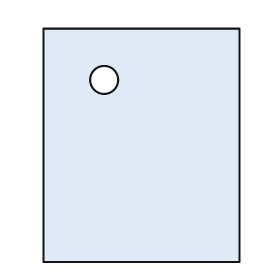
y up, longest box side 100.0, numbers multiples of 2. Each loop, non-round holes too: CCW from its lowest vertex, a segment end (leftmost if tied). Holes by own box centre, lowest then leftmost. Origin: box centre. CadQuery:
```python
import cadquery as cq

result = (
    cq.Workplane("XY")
    .moveTo(-42.0, -50.0)
    .lineTo(42.0, -50.0)
    .lineTo(42.0, 50.0)
    .lineTo(-42.0, 50.0)
    .close()
    .moveTo(-16.0, 28.0)
    .circle(6.0)
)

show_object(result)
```